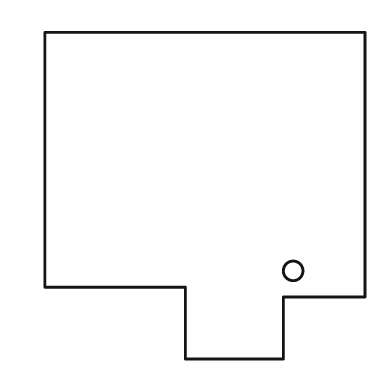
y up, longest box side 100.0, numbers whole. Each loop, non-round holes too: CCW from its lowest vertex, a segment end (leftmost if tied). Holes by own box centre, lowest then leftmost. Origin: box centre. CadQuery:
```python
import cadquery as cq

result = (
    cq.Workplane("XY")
    .moveTo(-6.0, -50.0)
    .lineTo(24.0, -50.0)
    .lineTo(24.0, -31.0)
    .lineTo(49.0, -31.0)
    .lineTo(49.0, 50.0)
    .lineTo(-49.0, 50.0)
    .lineTo(-49.0, -28.0)
    .lineTo(-6.0, -28.0)
    .close()
    .moveTo(27.0, -23.0)
    .circle(3.0)
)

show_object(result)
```